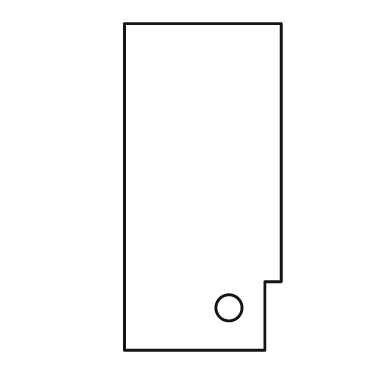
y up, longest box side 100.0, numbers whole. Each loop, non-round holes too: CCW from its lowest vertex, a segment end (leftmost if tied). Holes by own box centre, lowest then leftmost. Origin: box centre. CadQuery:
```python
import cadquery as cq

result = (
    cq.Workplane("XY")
    .moveTo(-24.0, -50.0)
    .lineTo(19.0, -50.0)
    .lineTo(19.0, -29.0)
    .lineTo(24.0, -29.0)
    .lineTo(24.0, 50.0)
    .lineTo(-24.0, 50.0)
    .close()
    .moveTo(8.0, -37.0)
    .circle(4.0)
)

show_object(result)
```